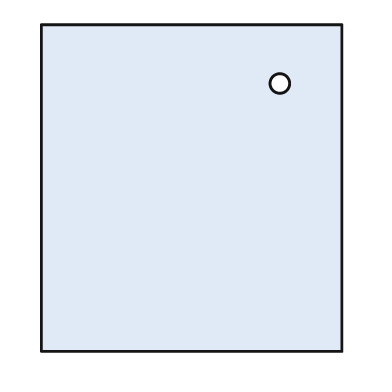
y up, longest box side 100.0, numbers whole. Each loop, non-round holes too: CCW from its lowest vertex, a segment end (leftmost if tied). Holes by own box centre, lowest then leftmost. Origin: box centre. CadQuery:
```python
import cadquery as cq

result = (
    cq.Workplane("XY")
    .moveTo(-46.0, -50.0)
    .lineTo(46.0, -50.0)
    .lineTo(46.0, 50.0)
    .lineTo(-46.0, 50.0)
    .close()
    .moveTo(27.0, 32.0)
    .circle(3.0)
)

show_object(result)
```